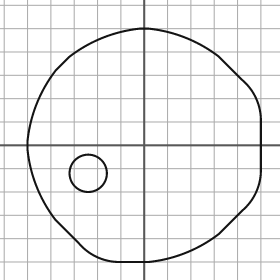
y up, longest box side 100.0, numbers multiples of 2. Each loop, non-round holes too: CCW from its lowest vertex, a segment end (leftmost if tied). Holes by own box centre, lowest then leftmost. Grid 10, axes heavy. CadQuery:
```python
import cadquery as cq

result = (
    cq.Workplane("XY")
    .moveTo(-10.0, -50.0)
    .lineTo(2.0, -50.0)
    .threePointArc((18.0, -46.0), (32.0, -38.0))
    .lineTo(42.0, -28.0)
    .threePointArc((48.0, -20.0), (50.0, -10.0))
    .lineTo(50.0, 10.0)
    .threePointArc((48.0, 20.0), (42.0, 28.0))
    .lineTo(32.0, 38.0)
    .threePointArc((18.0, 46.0), (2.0, 50.0))
    .lineTo(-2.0, 50.0)
    .threePointArc((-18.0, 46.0), (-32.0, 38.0))
    .lineTo(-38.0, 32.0)
    .threePointArc((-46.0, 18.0), (-50.0, 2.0))
    .lineTo(-50.0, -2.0)
    .threePointArc((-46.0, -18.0), (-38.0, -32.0))
    .lineTo(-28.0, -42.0)
    .threePointArc((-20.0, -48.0), (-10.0, -50.0))
    .close()
    .moveTo(-24.0, -12.0)
    .circle(8.0)
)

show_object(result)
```